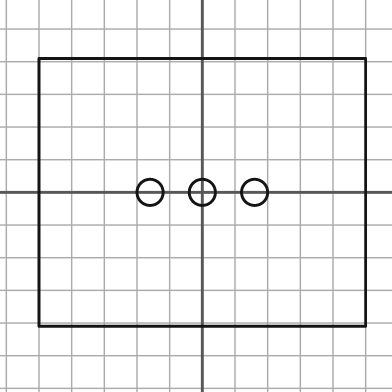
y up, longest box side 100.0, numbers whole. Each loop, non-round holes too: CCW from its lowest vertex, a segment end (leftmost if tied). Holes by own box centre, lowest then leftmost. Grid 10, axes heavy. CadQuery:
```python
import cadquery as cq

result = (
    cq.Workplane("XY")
    .moveTo(-50.0, -41.0)
    .lineTo(50.0, -41.0)
    .lineTo(50.0, 41.0)
    .lineTo(-50.0, 41.0)
    .close()
    .moveTo(-16.0, 0.0)
    .circle(4.0)
    .moveTo(0.0, 0.0)
    .circle(4.0)
    .moveTo(16.0, 0.0)
    .circle(4.0)
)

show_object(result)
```